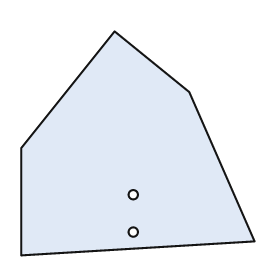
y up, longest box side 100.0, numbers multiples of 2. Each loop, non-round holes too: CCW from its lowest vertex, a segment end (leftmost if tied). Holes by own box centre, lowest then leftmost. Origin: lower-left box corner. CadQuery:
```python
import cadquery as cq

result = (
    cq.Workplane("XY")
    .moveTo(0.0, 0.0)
    .lineTo(100.0, 6.0)
    .lineTo(72.0, 70.0)
    .lineTo(40.0, 96.0)
    .lineTo(0.0, 46.0)
    .close()
    .moveTo(48.0, 10.0)
    .circle(2.0)
    .moveTo(48.0, 26.0)
    .circle(2.0)
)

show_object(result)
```